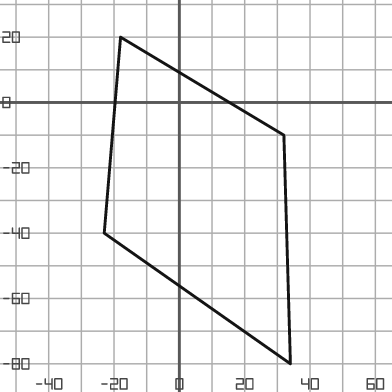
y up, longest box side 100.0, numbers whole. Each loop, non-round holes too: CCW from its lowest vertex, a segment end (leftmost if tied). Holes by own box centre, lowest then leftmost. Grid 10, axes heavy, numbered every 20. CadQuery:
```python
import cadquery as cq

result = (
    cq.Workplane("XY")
    .moveTo(34.0, -80.0)
    .lineTo(32.0, -10.0)
    .lineTo(-18.0, 20.0)
    .lineTo(-23.0, -40.0)
    .close()
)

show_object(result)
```